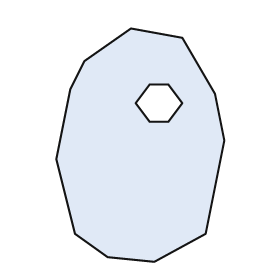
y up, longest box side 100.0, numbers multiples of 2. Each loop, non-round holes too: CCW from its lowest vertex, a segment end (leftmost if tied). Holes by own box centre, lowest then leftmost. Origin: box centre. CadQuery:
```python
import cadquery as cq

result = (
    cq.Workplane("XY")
    .moveTo(6.0, -50.0)
    .lineTo(28.0, -38.0)
    .lineTo(36.0, 2.0)
    .lineTo(32.0, 22.0)
    .lineTo(18.0, 46.0)
    .lineTo(-4.0, 50.0)
    .lineTo(-24.0, 36.0)
    .lineTo(-30.0, 24.0)
    .lineTo(-36.0, -6.0)
    .lineTo(-28.0, -38.0)
    .lineTo(-14.0, -48.0)
    .close()
    .moveTo(4.0, 10.0)
    .lineTo(12.0, 10.0)
    .lineTo(18.0, 18.0)
    .lineTo(12.0, 26.0)
    .lineTo(4.0, 26.0)
    .lineTo(-2.0, 18.0)
    .close()
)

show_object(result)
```